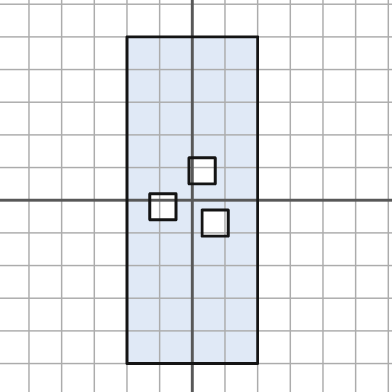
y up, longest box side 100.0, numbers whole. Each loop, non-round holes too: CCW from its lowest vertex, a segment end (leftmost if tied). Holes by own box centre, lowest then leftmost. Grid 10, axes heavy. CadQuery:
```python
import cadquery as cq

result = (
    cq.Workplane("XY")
    .moveTo(-20.0, -50.0)
    .lineTo(20.0, -50.0)
    .lineTo(20.0, 50.0)
    .lineTo(-20.0, 50.0)
    .close()
    .moveTo(3.0, -11.0)
    .lineTo(11.0, -11.0)
    .lineTo(11.0, -3.0)
    .lineTo(3.0, -3.0)
    .close()
    .moveTo(-13.0, -6.0)
    .lineTo(-5.0, -6.0)
    .lineTo(-5.0, 2.0)
    .lineTo(-13.0, 2.0)
    .close()
    .moveTo(-1.0, 5.0)
    .lineTo(7.0, 5.0)
    .lineTo(7.0, 13.0)
    .lineTo(-1.0, 13.0)
    .close()
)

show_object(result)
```